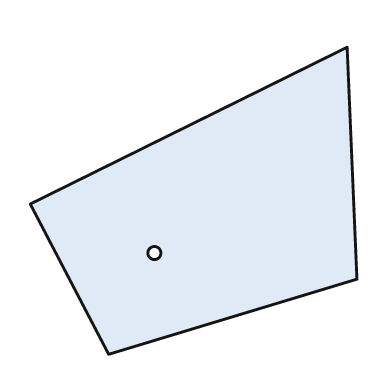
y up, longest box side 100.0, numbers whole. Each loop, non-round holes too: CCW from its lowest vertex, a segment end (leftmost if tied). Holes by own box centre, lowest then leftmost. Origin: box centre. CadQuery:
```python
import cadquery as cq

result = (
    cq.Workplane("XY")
    .moveTo(-26.0, -47.0)
    .lineTo(50.0, -24.0)
    .lineTo(47.0, 47.0)
    .lineTo(-50.0, -1.0)
    .close()
    .moveTo(-12.0, -16.0)
    .circle(2.0)
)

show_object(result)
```